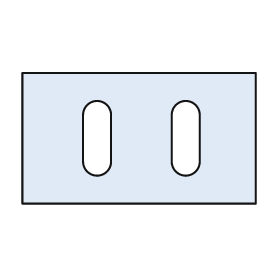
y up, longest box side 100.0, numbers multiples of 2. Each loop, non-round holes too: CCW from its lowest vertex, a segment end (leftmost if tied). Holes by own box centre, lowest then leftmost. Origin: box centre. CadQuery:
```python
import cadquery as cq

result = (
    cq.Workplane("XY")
    .moveTo(-50.0, -28.0)
    .lineTo(50.0, -28.0)
    .lineTo(50.0, 28.0)
    .lineTo(-50.0, 28.0)
    .close()
    .moveTo(-24.0, -10.0)
    .threePointArc((-18.0, -16.0), (-12.0, -10.0))
    .lineTo(-12.0, 10.0)
    .threePointArc((-18.0, 16.0), (-24.0, 10.0))
    .close()
    .moveTo(14.0, -10.0)
    .threePointArc((20.0, -16.0), (26.0, -10.0))
    .lineTo(26.0, 10.0)
    .threePointArc((20.0, 16.0), (14.0, 10.0))
    .close()
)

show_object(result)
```